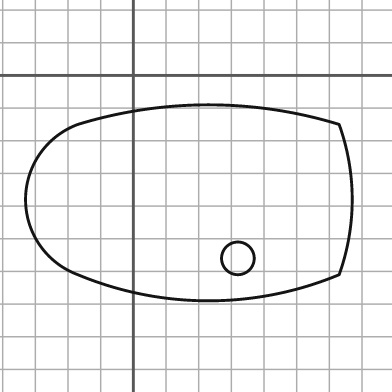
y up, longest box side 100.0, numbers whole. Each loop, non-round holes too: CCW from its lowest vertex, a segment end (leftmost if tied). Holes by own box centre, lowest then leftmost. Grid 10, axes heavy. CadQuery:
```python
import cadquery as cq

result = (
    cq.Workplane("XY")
    .moveTo(-17.0, -61.0)
    .threePointArc((23.0, -69.0), (63.0, -61.0))
    .threePointArc((67.0, -38.0), (63.0, -15.0))
    .threePointArc((23.0, -9.0), (-17.0, -15.0))
    .threePointArc((-33.0, -38.0), (-17.0, -61.0))
    .close()
    .moveTo(32.0, -56.0)
    .circle(5.0)
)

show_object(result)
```